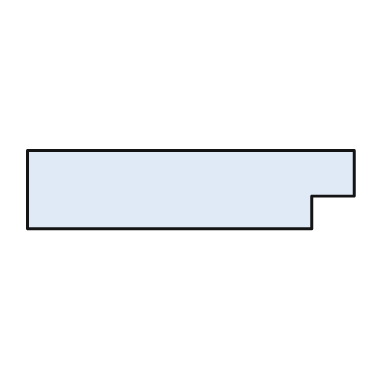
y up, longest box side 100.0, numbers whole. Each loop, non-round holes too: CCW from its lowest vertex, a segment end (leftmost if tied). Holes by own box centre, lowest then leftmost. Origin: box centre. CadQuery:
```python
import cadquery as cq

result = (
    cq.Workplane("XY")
    .moveTo(-50.0, -12.0)
    .lineTo(37.0, -12.0)
    .lineTo(37.0, -2.0)
    .lineTo(50.0, -2.0)
    .lineTo(50.0, 12.0)
    .lineTo(-50.0, 12.0)
    .close()
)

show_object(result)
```